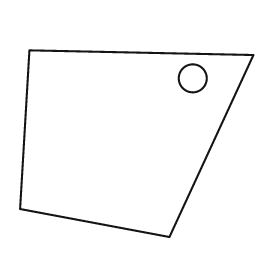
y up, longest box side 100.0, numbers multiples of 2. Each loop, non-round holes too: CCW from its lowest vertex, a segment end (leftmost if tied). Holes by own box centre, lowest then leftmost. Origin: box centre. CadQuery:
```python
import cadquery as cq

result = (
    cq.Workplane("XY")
    .moveTo(14.0, -40.0)
    .lineTo(50.0, 38.0)
    .lineTo(-46.0, 40.0)
    .lineTo(-50.0, -28.0)
    .close()
    .moveTo(24.0, 28.0)
    .circle(6.0)
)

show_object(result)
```